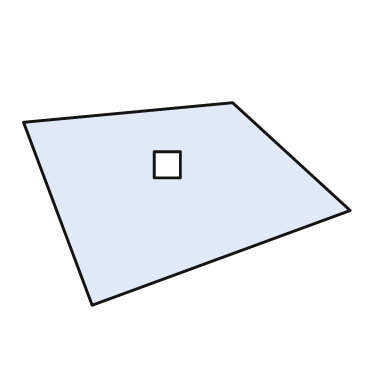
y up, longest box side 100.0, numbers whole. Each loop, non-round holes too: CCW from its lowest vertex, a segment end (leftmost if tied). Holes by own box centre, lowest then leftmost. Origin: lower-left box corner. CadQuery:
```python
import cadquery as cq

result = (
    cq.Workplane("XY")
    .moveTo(21.0, 0.0)
    .lineTo(100.0, 29.0)
    .lineTo(64.0, 62.0)
    .lineTo(0.0, 56.0)
    .close()
    .moveTo(40.0, 39.0)
    .lineTo(48.0, 39.0)
    .lineTo(48.0, 47.0)
    .lineTo(40.0, 47.0)
    .close()
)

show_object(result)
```